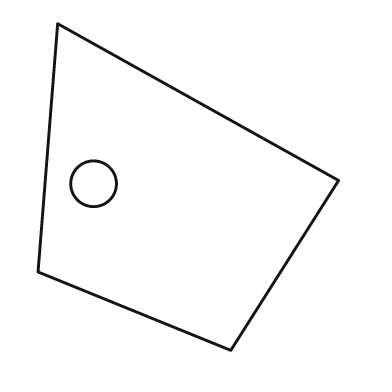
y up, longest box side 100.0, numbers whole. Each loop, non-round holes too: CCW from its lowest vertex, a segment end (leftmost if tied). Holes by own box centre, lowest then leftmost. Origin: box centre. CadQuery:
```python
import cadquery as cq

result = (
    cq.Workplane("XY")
    .moveTo(13.0, -50.0)
    .lineTo(46.0, 2.0)
    .lineTo(-40.0, 50.0)
    .lineTo(-46.0, -26.0)
    .close()
    .moveTo(-29.0, 1.0)
    .circle(7.0)
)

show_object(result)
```